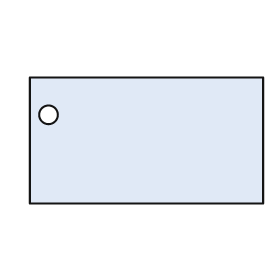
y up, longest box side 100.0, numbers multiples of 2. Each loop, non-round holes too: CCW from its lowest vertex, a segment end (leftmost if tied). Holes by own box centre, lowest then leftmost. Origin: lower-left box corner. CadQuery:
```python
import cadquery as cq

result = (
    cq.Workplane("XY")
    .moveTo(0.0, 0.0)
    .lineTo(100.0, 0.0)
    .lineTo(100.0, 54.0)
    .lineTo(0.0, 54.0)
    .close()
    .moveTo(8.0, 38.0)
    .circle(4.0)
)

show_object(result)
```